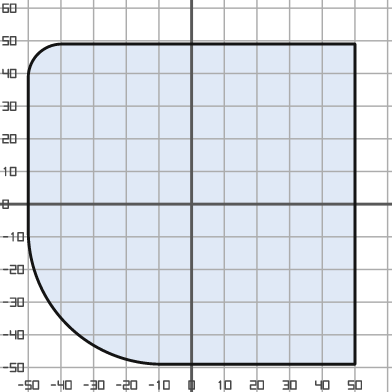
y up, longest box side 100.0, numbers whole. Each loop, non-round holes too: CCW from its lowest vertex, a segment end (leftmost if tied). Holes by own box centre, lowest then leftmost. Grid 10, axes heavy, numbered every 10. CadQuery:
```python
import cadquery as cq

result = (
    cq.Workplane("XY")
    .moveTo(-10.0, -49.0)
    .lineTo(50.0, -49.0)
    .lineTo(50.0, 49.0)
    .lineTo(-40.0, 49.0)
    .threePointArc((-47.0, 46.0), (-50.0, 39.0))
    .lineTo(-50.0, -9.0)
    .threePointArc((-38.0, -37.0), (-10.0, -49.0))
    .close()
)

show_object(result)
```